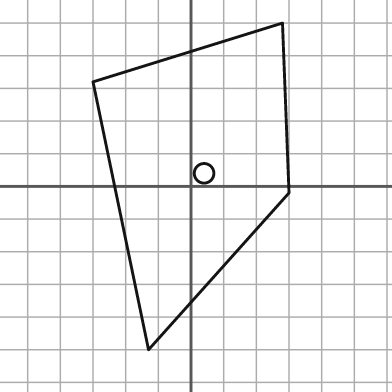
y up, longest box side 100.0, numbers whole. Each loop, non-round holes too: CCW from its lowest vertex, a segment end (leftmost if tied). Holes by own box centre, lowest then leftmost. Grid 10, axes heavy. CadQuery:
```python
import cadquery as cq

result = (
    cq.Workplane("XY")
    .moveTo(-13.0, -50.0)
    .lineTo(30.0, -2.0)
    .lineTo(28.0, 50.0)
    .lineTo(-30.0, 32.0)
    .close()
    .moveTo(4.0, 4.0)
    .circle(3.0)
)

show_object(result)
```